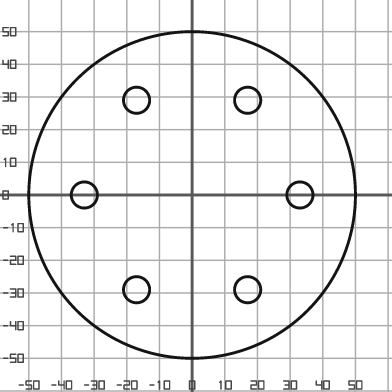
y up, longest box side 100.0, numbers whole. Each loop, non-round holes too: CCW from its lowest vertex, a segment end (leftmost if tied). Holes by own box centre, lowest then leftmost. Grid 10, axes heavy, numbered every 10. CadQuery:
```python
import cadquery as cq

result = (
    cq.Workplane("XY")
    .moveTo(0.0, 0.0)
    .circle(50.0)
    .moveTo(-17.0, -29.0)
    .circle(4.0)
    .moveTo(17.0, -29.0)
    .circle(4.0)
    .moveTo(-33.0, 0.0)
    .circle(4.0)
    .moveTo(33.0, 0.0)
    .circle(4.0)
    .moveTo(-17.0, 29.0)
    .circle(4.0)
    .moveTo(17.0, 29.0)
    .circle(4.0)
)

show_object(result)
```